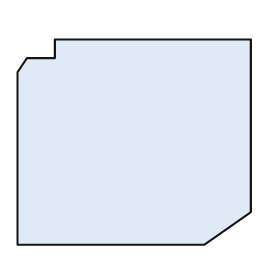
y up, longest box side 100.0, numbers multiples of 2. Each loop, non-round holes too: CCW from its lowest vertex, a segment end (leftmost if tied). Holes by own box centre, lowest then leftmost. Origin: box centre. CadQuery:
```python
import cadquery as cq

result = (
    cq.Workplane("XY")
    .moveTo(-50.0, -44.0)
    .lineTo(30.0, -44.0)
    .lineTo(50.0, -30.0)
    .lineTo(50.0, 44.0)
    .lineTo(-34.0, 44.0)
    .lineTo(-34.0, 36.0)
    .lineTo(-46.0, 36.0)
    .lineTo(-50.0, 30.0)
    .close()
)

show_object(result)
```